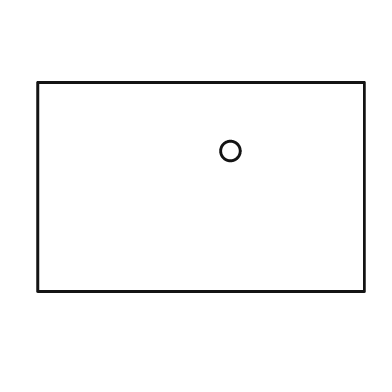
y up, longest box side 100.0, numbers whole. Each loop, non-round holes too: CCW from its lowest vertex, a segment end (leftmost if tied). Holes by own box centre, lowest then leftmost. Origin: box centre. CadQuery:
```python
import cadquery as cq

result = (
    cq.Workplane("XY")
    .moveTo(-50.0, -32.0)
    .lineTo(50.0, -32.0)
    .lineTo(50.0, 32.0)
    .lineTo(-50.0, 32.0)
    .close()
    .moveTo(9.0, 11.0)
    .circle(3.0)
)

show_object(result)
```